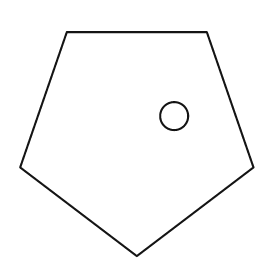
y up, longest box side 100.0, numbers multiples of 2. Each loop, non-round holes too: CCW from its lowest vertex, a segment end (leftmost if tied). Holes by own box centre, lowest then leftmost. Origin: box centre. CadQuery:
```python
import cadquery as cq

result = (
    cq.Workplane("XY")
    .moveTo(0.0, -48.0)
    .lineTo(50.0, -10.0)
    .lineTo(30.0, 48.0)
    .lineTo(-30.0, 48.0)
    .lineTo(-50.0, -10.0)
    .close()
    .moveTo(16.0, 12.0)
    .circle(6.0)
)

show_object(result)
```